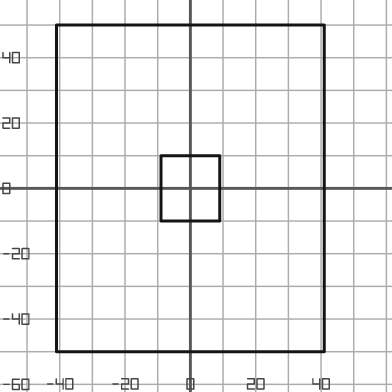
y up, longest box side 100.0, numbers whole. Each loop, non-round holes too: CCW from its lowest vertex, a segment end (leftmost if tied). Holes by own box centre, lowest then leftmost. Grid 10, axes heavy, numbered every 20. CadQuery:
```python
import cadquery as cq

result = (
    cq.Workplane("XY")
    .moveTo(-41.0, -50.0)
    .lineTo(41.0, -50.0)
    .lineTo(41.0, 50.0)
    .lineTo(-41.0, 50.0)
    .close()
    .moveTo(-9.0, -10.0)
    .lineTo(9.0, -10.0)
    .lineTo(9.0, 10.0)
    .lineTo(-9.0, 10.0)
    .close()
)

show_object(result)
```